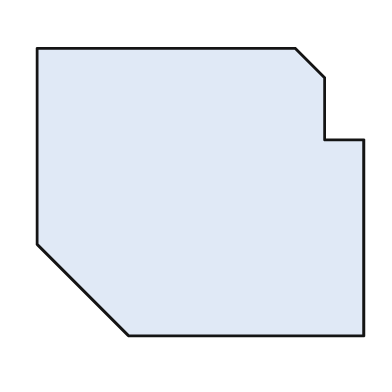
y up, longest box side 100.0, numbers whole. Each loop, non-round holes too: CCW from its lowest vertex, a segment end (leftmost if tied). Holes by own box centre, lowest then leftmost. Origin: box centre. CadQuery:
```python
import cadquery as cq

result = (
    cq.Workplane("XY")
    .moveTo(-22.0, -44.0)
    .lineTo(50.0, -44.0)
    .lineTo(50.0, 16.0)
    .lineTo(38.0, 16.0)
    .lineTo(38.0, 35.0)
    .lineTo(29.0, 44.0)
    .lineTo(-50.0, 44.0)
    .lineTo(-50.0, -16.0)
    .close()
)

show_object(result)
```